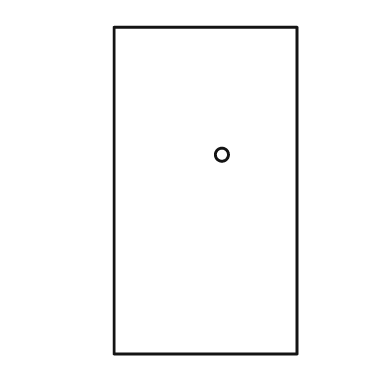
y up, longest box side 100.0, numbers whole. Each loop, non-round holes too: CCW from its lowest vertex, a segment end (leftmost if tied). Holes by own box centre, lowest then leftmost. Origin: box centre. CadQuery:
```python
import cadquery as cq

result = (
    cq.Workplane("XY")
    .moveTo(-28.0, -50.0)
    .lineTo(28.0, -50.0)
    .lineTo(28.0, 50.0)
    .lineTo(-28.0, 50.0)
    .close()
    .moveTo(5.0, 11.0)
    .circle(2.0)
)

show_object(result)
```